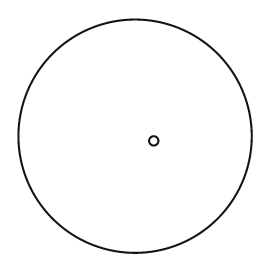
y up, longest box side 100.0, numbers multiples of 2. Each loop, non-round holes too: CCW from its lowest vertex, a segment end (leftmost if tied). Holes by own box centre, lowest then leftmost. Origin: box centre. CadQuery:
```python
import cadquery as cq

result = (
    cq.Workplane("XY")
    .moveTo(0.0, 0.0)
    .circle(50.0)
    .moveTo(8.0, -2.0)
    .circle(2.0)
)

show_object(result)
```